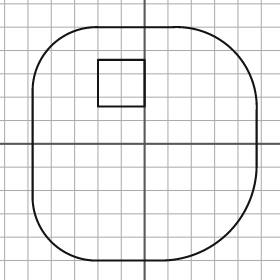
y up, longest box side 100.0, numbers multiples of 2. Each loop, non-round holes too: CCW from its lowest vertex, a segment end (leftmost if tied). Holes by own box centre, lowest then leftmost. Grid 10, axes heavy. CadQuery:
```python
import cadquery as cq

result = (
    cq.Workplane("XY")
    .moveTo(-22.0, -50.0)
    .lineTo(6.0, -50.0)
    .threePointArc((36.0, -38.0), (48.0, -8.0))
    .lineTo(48.0, 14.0)
    .threePointArc((38.0, 40.0), (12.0, 50.0))
    .lineTo(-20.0, 50.0)
    .threePointArc((-40.0, 42.0), (-48.0, 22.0))
    .lineTo(-48.0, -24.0)
    .threePointArc((-40.0, -42.0), (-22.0, -50.0))
    .close()
    .moveTo(-20.0, 16.0)
    .lineTo(0.0, 16.0)
    .lineTo(0.0, 36.0)
    .lineTo(-20.0, 36.0)
    .close()
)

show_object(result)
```